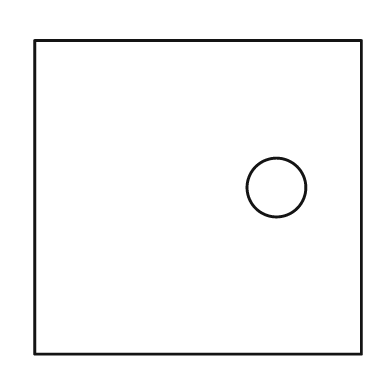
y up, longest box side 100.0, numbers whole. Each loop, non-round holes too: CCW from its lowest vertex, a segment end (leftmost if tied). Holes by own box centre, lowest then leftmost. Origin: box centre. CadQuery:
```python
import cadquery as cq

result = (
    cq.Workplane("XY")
    .moveTo(-50.0, -48.0)
    .lineTo(50.0, -48.0)
    .lineTo(50.0, 48.0)
    .lineTo(-50.0, 48.0)
    .close()
    .moveTo(24.0, 3.0)
    .circle(9.0)
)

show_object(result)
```